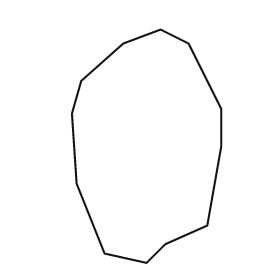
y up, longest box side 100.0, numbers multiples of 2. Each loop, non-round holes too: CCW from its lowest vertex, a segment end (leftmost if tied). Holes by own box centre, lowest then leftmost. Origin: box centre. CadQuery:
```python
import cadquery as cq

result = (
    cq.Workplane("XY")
    .moveTo(0.0, -50.0)
    .lineTo(8.0, -42.0)
    .lineTo(26.0, -34.0)
    .lineTo(32.0, 0.0)
    .lineTo(32.0, 16.0)
    .lineTo(18.0, 44.0)
    .lineTo(6.0, 50.0)
    .lineTo(-10.0, 44.0)
    .lineTo(-28.0, 28.0)
    .lineTo(-32.0, 14.0)
    .lineTo(-30.0, -16.0)
    .lineTo(-18.0, -46.0)
    .close()
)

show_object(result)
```